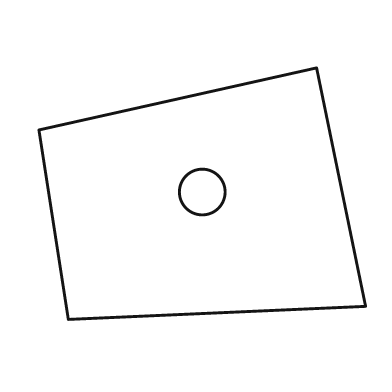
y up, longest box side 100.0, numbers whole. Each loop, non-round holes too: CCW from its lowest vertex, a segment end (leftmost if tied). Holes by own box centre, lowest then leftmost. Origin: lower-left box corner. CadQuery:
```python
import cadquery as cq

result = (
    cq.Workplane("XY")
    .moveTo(9.0, 0.0)
    .lineTo(100.0, 4.0)
    .lineTo(85.0, 77.0)
    .lineTo(0.0, 58.0)
    .close()
    .moveTo(50.0, 39.0)
    .circle(7.0)
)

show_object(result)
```